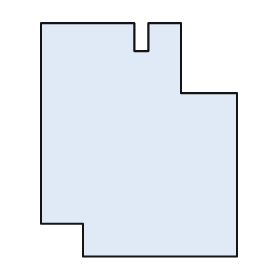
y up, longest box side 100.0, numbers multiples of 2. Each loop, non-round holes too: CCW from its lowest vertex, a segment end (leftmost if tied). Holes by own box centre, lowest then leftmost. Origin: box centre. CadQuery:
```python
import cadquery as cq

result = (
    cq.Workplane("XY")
    .moveTo(-24.0, -50.0)
    .lineTo(42.0, -50.0)
    .lineTo(42.0, 20.0)
    .lineTo(18.0, 20.0)
    .lineTo(18.0, 50.0)
    .lineTo(4.0, 50.0)
    .lineTo(4.0, 38.0)
    .lineTo(-2.0, 38.0)
    .lineTo(-2.0, 50.0)
    .lineTo(-42.0, 50.0)
    .lineTo(-42.0, -36.0)
    .lineTo(-24.0, -36.0)
    .close()
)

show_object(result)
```